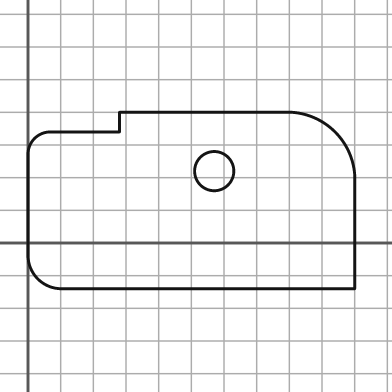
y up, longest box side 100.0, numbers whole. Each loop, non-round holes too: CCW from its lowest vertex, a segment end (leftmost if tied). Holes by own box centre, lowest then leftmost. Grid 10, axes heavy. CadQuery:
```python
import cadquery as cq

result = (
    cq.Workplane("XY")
    .moveTo(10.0, -14.0)
    .lineTo(100.0, -14.0)
    .lineTo(100.0, 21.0)
    .threePointArc((94.0, 34.0), (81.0, 40.0))
    .lineTo(28.0, 40.0)
    .lineTo(28.0, 34.0)
    .lineTo(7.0, 34.0)
    .threePointArc((2.0, 32.0), (0.0, 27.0))
    .lineTo(0.0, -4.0)
    .threePointArc((3.0, -11.0), (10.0, -14.0))
    .close()
    .moveTo(57.0, 22.0)
    .circle(6.0)
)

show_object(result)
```